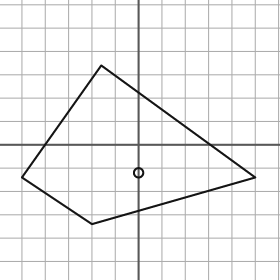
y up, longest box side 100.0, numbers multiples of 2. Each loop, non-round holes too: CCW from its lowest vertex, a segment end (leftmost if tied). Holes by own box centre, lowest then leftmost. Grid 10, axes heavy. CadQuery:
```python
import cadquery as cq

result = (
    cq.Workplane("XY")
    .moveTo(-20.0, -34.0)
    .lineTo(50.0, -14.0)
    .lineTo(-16.0, 34.0)
    .lineTo(-50.0, -14.0)
    .close()
    .moveTo(0.0, -12.0)
    .circle(2.0)
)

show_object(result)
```